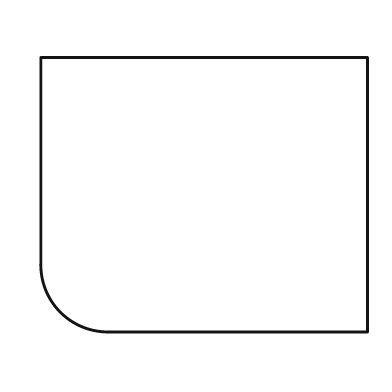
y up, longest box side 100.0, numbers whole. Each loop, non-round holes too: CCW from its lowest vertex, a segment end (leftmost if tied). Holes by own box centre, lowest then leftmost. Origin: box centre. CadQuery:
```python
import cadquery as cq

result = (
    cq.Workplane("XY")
    .moveTo(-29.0, -42.0)
    .lineTo(50.0, -42.0)
    .lineTo(50.0, 42.0)
    .lineTo(-50.0, 42.0)
    .lineTo(-50.0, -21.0)
    .threePointArc((-44.0, -36.0), (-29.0, -42.0))
    .close()
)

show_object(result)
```